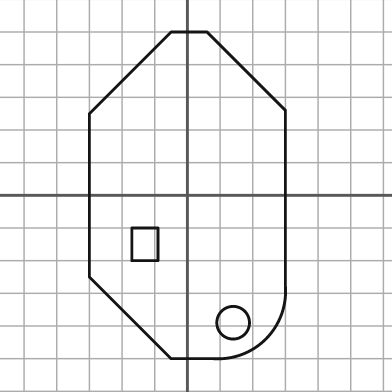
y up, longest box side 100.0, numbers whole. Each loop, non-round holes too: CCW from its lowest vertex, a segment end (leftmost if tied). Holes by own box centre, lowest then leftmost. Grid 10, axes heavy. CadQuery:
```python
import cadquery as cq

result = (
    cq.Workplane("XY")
    .moveTo(-5.0, -50.0)
    .lineTo(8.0, -50.0)
    .threePointArc((24.0, -44.0), (30.0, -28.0))
    .lineTo(30.0, 26.0)
    .lineTo(6.0, 50.0)
    .lineTo(-5.0, 50.0)
    .lineTo(-30.0, 25.0)
    .lineTo(-30.0, -25.0)
    .close()
    .moveTo(14.0, -39.0)
    .circle(5.0)
    .moveTo(-17.0, -20.0)
    .lineTo(-9.0, -20.0)
    .lineTo(-9.0, -10.0)
    .lineTo(-17.0, -10.0)
    .close()
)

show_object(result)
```